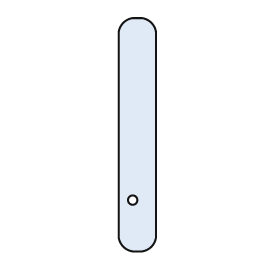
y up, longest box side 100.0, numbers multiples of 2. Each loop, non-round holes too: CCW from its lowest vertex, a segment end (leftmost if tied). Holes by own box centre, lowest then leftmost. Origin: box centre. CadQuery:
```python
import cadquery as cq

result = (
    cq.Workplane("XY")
    .moveTo(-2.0, -50.0)
    .lineTo(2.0, -50.0)
    .threePointArc((6.0, -48.0), (8.0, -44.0))
    .lineTo(8.0, 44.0)
    .threePointArc((6.0, 48.0), (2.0, 50.0))
    .lineTo(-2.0, 50.0)
    .threePointArc((-6.0, 48.0), (-8.0, 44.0))
    .lineTo(-8.0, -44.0)
    .threePointArc((-6.0, -48.0), (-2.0, -50.0))
    .close()
    .moveTo(-2.0, -28.0)
    .circle(2.0)
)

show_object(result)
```